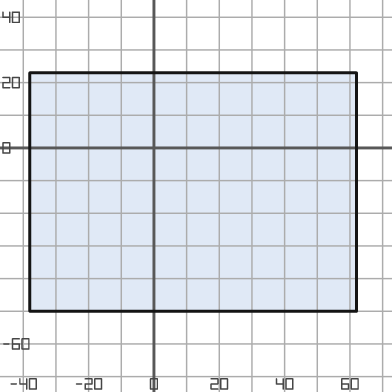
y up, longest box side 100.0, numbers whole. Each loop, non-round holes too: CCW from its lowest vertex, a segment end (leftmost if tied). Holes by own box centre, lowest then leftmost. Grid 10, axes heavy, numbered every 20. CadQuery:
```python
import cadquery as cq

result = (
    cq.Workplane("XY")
    .moveTo(-38.0, -50.0)
    .lineTo(62.0, -50.0)
    .lineTo(62.0, 23.0)
    .lineTo(-38.0, 23.0)
    .close()
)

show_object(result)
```